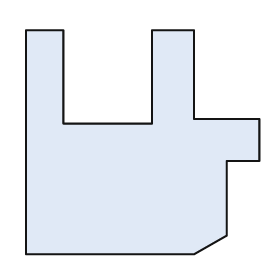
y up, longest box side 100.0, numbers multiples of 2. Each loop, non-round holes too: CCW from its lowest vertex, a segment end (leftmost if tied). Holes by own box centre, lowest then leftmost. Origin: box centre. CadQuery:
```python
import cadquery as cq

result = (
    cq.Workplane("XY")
    .moveTo(-50.0, -48.0)
    .lineTo(22.0, -48.0)
    .lineTo(36.0, -40.0)
    .lineTo(36.0, -8.0)
    .lineTo(50.0, -8.0)
    .lineTo(50.0, 10.0)
    .lineTo(22.0, 10.0)
    .lineTo(22.0, 48.0)
    .lineTo(4.0, 48.0)
    .lineTo(4.0, 8.0)
    .lineTo(-34.0, 8.0)
    .lineTo(-34.0, 48.0)
    .lineTo(-50.0, 48.0)
    .close()
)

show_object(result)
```